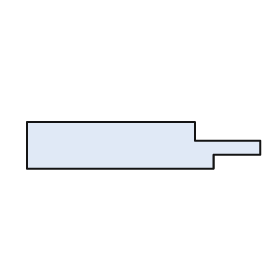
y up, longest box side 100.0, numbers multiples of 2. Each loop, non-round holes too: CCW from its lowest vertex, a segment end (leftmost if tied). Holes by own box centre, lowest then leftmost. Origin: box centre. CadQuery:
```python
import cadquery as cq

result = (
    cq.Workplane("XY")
    .moveTo(-50.0, -10.0)
    .lineTo(30.0, -10.0)
    .lineTo(30.0, -4.0)
    .lineTo(50.0, -4.0)
    .lineTo(50.0, 2.0)
    .lineTo(22.0, 2.0)
    .lineTo(22.0, 10.0)
    .lineTo(-50.0, 10.0)
    .close()
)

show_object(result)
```